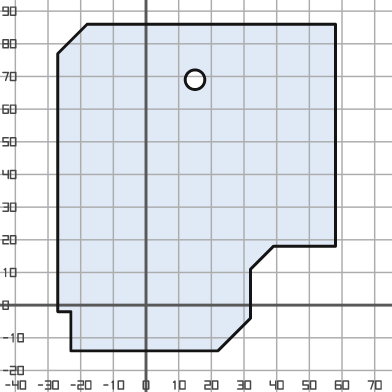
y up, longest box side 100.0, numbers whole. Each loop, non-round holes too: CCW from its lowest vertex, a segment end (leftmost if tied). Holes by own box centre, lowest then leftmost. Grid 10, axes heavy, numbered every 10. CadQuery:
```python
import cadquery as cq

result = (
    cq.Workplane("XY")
    .moveTo(-23.0, -14.0)
    .lineTo(22.0, -14.0)
    .lineTo(32.0, -4.0)
    .lineTo(32.0, 11.0)
    .lineTo(39.0, 18.0)
    .lineTo(58.0, 18.0)
    .lineTo(58.0, 86.0)
    .lineTo(-18.0, 86.0)
    .lineTo(-27.0, 77.0)
    .lineTo(-27.0, -2.0)
    .lineTo(-23.0, -2.0)
    .close()
    .moveTo(15.0, 69.0)
    .circle(3.0)
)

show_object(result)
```